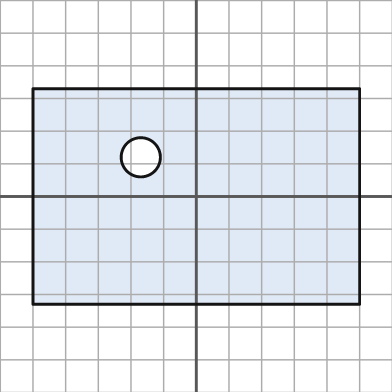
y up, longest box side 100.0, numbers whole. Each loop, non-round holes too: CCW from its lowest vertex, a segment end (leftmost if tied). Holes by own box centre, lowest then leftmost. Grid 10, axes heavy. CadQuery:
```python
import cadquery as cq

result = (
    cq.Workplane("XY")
    .moveTo(-50.0, -33.0)
    .lineTo(50.0, -33.0)
    .lineTo(50.0, 33.0)
    .lineTo(-50.0, 33.0)
    .close()
    .moveTo(-17.0, 12.0)
    .circle(6.0)
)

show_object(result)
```